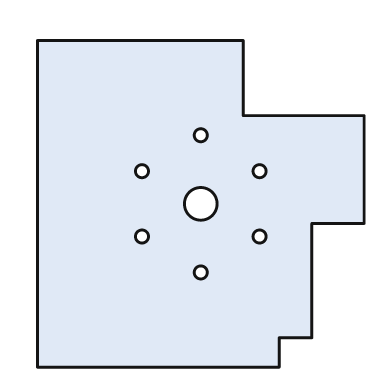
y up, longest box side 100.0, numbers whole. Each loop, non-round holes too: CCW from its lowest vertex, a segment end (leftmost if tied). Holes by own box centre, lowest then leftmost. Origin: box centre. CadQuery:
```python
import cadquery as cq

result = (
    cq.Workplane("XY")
    .moveTo(-50.0, -50.0)
    .lineTo(24.0, -50.0)
    .lineTo(24.0, -41.0)
    .lineTo(34.0, -41.0)
    .lineTo(34.0, -6.0)
    .lineTo(50.0, -6.0)
    .lineTo(50.0, 27.0)
    .lineTo(13.0, 27.0)
    .lineTo(13.0, 50.0)
    .lineTo(-50.0, 50.0)
    .close()
    .moveTo(0.0, -21.0)
    .circle(2.0)
    .moveTo(-18.0, -10.0)
    .circle(2.0)
    .moveTo(18.0, -10.0)
    .circle(2.0)
    .moveTo(0.0, 0.0)
    .circle(5.0)
    .moveTo(-18.0, 10.0)
    .circle(2.0)
    .moveTo(18.0, 10.0)
    .circle(2.0)
    .moveTo(0.0, 21.0)
    .circle(2.0)
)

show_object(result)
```